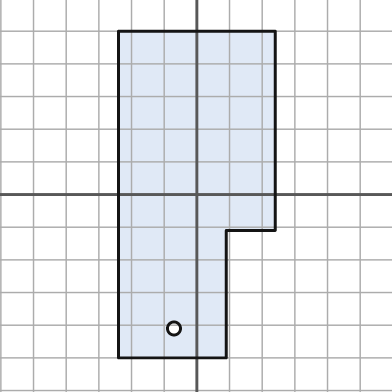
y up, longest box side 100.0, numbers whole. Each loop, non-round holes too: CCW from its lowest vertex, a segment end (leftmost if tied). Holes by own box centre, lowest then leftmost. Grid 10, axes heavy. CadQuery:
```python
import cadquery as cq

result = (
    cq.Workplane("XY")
    .moveTo(-24.0, -50.0)
    .lineTo(9.0, -50.0)
    .lineTo(9.0, -11.0)
    .lineTo(24.0, -11.0)
    .lineTo(24.0, 50.0)
    .lineTo(-24.0, 50.0)
    .close()
    .moveTo(-7.0, -41.0)
    .circle(2.0)
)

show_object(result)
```